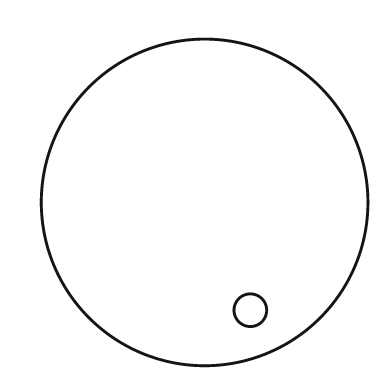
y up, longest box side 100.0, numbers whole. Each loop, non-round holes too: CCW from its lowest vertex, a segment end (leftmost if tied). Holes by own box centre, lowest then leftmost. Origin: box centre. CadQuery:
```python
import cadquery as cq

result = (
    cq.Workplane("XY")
    .moveTo(0.0, 0.0)
    .circle(50.0)
    .moveTo(14.0, -33.0)
    .circle(5.0)
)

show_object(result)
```